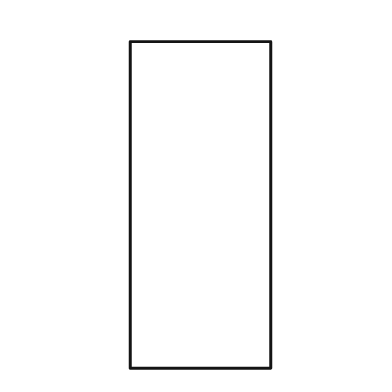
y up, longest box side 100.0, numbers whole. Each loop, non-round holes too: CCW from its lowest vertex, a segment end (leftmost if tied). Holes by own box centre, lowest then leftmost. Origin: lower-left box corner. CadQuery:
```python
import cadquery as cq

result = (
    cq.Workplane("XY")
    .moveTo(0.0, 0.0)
    .lineTo(43.0, 0.0)
    .lineTo(43.0, 100.0)
    .lineTo(0.0, 100.0)
    .close()
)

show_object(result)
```